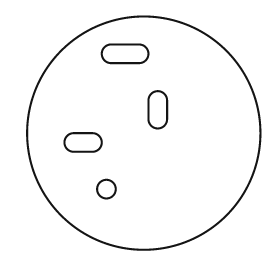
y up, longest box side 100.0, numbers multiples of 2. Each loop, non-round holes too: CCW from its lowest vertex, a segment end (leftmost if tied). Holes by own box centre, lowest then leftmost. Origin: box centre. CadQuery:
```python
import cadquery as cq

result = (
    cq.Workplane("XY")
    .moveTo(0.0, 0.0)
    .circle(50.0)
    .moveTo(-16.0, -24.0)
    .circle(4.0)
    .moveTo(-30.0, -8.0)
    .lineTo(-22.0, -8.0)
    .threePointArc((-18.0, -4.0), (-22.0, 0.0))
    .lineTo(-30.0, 0.0)
    .threePointArc((-34.0, -4.0), (-30.0, -8.0))
    .close()
    .moveTo(2.0, 6.0)
    .threePointArc((6.0, 2.0), (10.0, 6.0))
    .lineTo(10.0, 14.0)
    .threePointArc((6.0, 18.0), (2.0, 14.0))
    .close()
    .moveTo(-14.0, 30.0)
    .lineTo(-2.0, 30.0)
    .threePointArc((2.0, 34.0), (-2.0, 38.0))
    .lineTo(-14.0, 38.0)
    .threePointArc((-18.0, 34.0), (-14.0, 30.0))
    .close()
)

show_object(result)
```